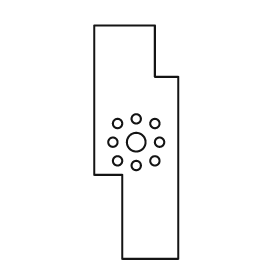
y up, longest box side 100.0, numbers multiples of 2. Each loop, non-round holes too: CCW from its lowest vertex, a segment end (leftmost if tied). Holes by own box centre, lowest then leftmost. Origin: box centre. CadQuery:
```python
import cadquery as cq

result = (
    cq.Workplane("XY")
    .moveTo(-6.0, -50.0)
    .lineTo(18.0, -50.0)
    .lineTo(18.0, 28.0)
    .lineTo(8.0, 28.0)
    .lineTo(8.0, 50.0)
    .lineTo(-18.0, 50.0)
    .lineTo(-18.0, -14.0)
    .lineTo(-6.0, -14.0)
    .close()
    .moveTo(0.0, -10.0)
    .circle(2.0)
    .moveTo(-8.0, -8.0)
    .circle(2.0)
    .moveTo(8.0, -8.0)
    .circle(2.0)
    .moveTo(-10.0, 0.0)
    .circle(2.0)
    .moveTo(0.0, 0.0)
    .circle(4.0)
    .moveTo(10.0, 0.0)
    .circle(2.0)
    .moveTo(-8.0, 8.0)
    .circle(2.0)
    .moveTo(8.0, 8.0)
    .circle(2.0)
    .moveTo(0.0, 10.0)
    .circle(2.0)
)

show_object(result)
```